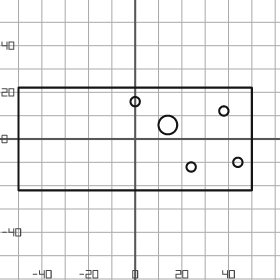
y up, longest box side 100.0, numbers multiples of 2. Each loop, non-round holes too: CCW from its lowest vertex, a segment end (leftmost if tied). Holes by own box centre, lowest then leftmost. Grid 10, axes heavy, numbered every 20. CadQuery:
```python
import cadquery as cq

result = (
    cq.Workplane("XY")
    .moveTo(-50.0, -22.0)
    .lineTo(50.0, -22.0)
    .lineTo(50.0, 22.0)
    .lineTo(-50.0, 22.0)
    .close()
    .moveTo(24.0, -12.0)
    .circle(2.0)
    .moveTo(44.0, -10.0)
    .circle(2.0)
    .moveTo(14.0, 6.0)
    .circle(4.0)
    .moveTo(38.0, 12.0)
    .circle(2.0)
    .moveTo(0.0, 16.0)
    .circle(2.0)
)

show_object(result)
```